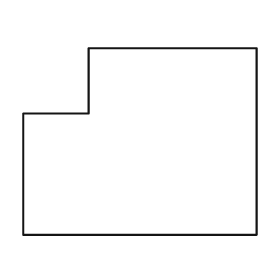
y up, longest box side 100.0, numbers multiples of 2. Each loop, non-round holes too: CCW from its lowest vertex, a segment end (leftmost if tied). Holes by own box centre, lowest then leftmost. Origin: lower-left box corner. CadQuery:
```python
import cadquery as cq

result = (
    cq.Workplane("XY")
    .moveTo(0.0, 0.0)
    .lineTo(100.0, 0.0)
    .lineTo(100.0, 80.0)
    .lineTo(28.0, 80.0)
    .lineTo(28.0, 52.0)
    .lineTo(0.0, 52.0)
    .close()
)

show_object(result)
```